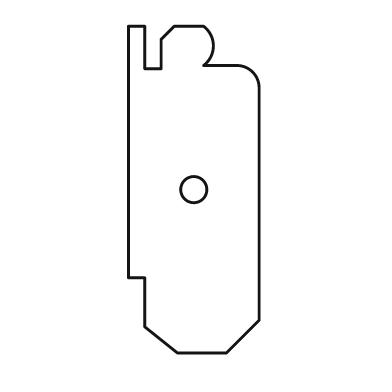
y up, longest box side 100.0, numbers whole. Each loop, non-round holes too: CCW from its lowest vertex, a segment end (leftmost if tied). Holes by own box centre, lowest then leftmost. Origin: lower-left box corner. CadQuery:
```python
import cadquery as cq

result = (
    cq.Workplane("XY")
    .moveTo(15.0, 0.0)
    .lineTo(30.0, 0.0)
    .lineTo(40.0, 10.0)
    .lineTo(40.0, 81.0)
    .threePointArc((38.0, 86.0), (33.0, 88.0))
    .lineTo(23.0, 88.0)
    .threePointArc((26.0, 94.0), (23.0, 100.0))
    .lineTo(14.0, 100.0)
    .lineTo(10.0, 96.0)
    .lineTo(10.0, 87.0)
    .lineTo(5.0, 87.0)
    .lineTo(5.0, 100.0)
    .lineTo(0.0, 100.0)
    .lineTo(0.0, 23.0)
    .lineTo(5.0, 23.0)
    .lineTo(5.0, 8.0)
    .close()
    .moveTo(20.0, 50.0)
    .circle(4.0)
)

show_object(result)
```